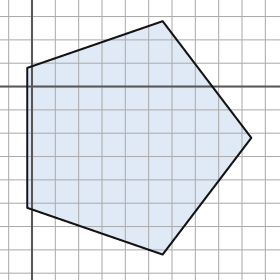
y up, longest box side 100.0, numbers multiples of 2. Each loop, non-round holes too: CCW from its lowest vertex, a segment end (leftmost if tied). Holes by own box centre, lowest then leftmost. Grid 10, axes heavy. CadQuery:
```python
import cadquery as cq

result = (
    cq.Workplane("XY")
    .moveTo(56.0, -72.0)
    .lineTo(94.0, -22.0)
    .lineTo(56.0, 28.0)
    .lineTo(-2.0, 8.0)
    .lineTo(-2.0, -52.0)
    .close()
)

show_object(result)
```